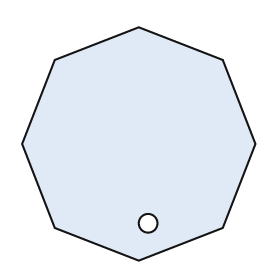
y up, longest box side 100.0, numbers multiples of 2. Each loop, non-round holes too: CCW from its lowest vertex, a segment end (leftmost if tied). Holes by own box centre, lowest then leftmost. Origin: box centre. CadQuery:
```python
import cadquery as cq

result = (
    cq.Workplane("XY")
    .moveTo(0.0, -50.0)
    .lineTo(36.0, -36.0)
    .lineTo(50.0, 0.0)
    .lineTo(36.0, 36.0)
    .lineTo(0.0, 50.0)
    .lineTo(-36.0, 36.0)
    .lineTo(-50.0, 0.0)
    .lineTo(-36.0, -36.0)
    .close()
    .moveTo(4.0, -34.0)
    .circle(4.0)
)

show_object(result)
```